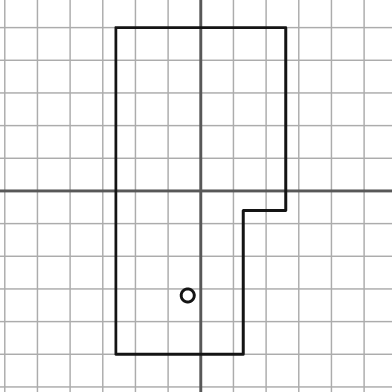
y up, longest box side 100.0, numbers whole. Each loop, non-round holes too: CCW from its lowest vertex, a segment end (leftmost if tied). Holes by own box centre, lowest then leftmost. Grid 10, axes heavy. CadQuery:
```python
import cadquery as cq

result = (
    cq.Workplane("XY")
    .moveTo(-26.0, -50.0)
    .lineTo(13.0, -50.0)
    .lineTo(13.0, -6.0)
    .lineTo(26.0, -6.0)
    .lineTo(26.0, 50.0)
    .lineTo(-26.0, 50.0)
    .close()
    .moveTo(-4.0, -32.0)
    .circle(2.0)
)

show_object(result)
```